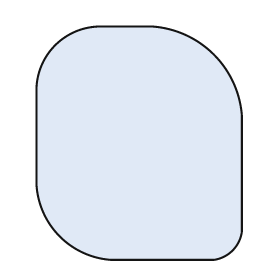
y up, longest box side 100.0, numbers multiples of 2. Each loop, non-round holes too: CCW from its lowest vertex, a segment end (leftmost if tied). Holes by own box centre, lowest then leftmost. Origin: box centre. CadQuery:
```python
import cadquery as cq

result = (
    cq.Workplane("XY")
    .moveTo(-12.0, -50.0)
    .lineTo(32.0, -50.0)
    .threePointArc((40.0, -46.0), (44.0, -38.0))
    .lineTo(44.0, 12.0)
    .threePointArc((32.0, 38.0), (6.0, 50.0))
    .lineTo(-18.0, 50.0)
    .threePointArc((-36.0, 42.0), (-44.0, 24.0))
    .lineTo(-44.0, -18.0)
    .threePointArc((-34.0, -40.0), (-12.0, -50.0))
    .close()
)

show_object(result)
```